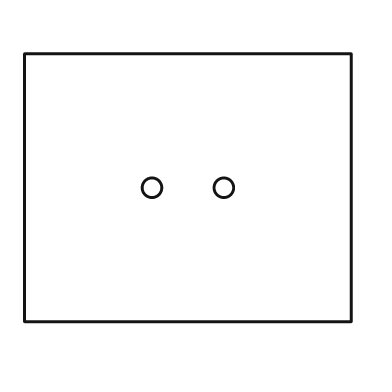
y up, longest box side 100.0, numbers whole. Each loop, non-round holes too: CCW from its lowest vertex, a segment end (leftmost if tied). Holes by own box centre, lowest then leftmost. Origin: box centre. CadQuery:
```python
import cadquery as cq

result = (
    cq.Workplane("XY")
    .moveTo(-50.0, -41.0)
    .lineTo(50.0, -41.0)
    .lineTo(50.0, 41.0)
    .lineTo(-50.0, 41.0)
    .close()
    .moveTo(-11.0, 0.0)
    .circle(3.0)
    .moveTo(11.0, 0.0)
    .circle(3.0)
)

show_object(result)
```